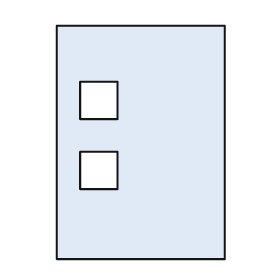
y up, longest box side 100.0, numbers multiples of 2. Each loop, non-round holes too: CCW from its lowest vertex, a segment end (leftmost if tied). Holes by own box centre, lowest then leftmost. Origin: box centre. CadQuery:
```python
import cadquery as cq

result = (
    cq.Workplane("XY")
    .moveTo(-36.0, -50.0)
    .lineTo(36.0, -50.0)
    .lineTo(36.0, 50.0)
    .lineTo(-36.0, 50.0)
    .close()
    .moveTo(-26.0, -20.0)
    .lineTo(-10.0, -20.0)
    .lineTo(-10.0, -4.0)
    .lineTo(-26.0, -4.0)
    .close()
    .moveTo(-26.0, 10.0)
    .lineTo(-10.0, 10.0)
    .lineTo(-10.0, 26.0)
    .lineTo(-26.0, 26.0)
    .close()
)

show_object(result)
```